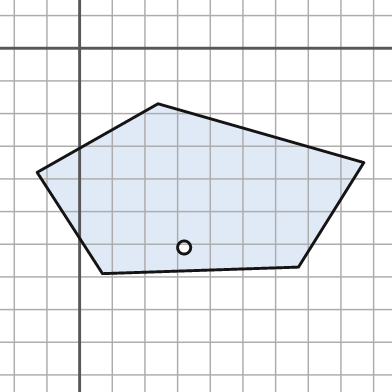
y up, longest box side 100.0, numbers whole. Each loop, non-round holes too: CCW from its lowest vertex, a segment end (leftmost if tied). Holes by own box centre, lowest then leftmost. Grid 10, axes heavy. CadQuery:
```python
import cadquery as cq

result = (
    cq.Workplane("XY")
    .moveTo(7.0, -69.0)
    .lineTo(67.0, -67.0)
    .lineTo(87.0, -35.0)
    .lineTo(24.0, -17.0)
    .lineTo(-13.0, -38.0)
    .close()
    .moveTo(32.0, -61.0)
    .circle(2.0)
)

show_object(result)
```